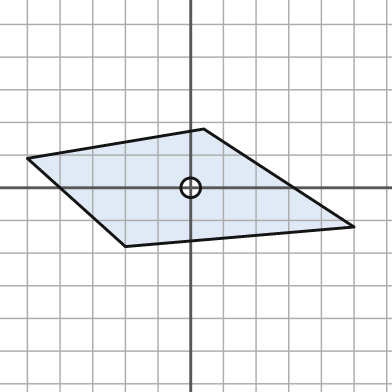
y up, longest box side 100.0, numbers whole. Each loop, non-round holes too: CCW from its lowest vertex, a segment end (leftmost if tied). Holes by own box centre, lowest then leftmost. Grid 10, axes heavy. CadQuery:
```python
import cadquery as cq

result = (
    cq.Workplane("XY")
    .moveTo(-20.0, -18.0)
    .lineTo(50.0, -12.0)
    .lineTo(4.0, 18.0)
    .lineTo(-50.0, 9.0)
    .close()
    .moveTo(0.0, 0.0)
    .circle(3.0)
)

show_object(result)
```